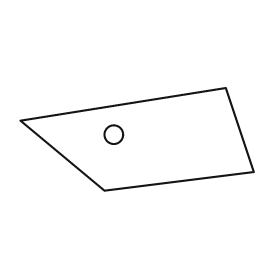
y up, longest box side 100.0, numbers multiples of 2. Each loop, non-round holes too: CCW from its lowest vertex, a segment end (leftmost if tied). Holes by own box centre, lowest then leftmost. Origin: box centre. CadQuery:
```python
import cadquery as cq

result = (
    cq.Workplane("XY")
    .moveTo(-14.0, -22.0)
    .lineTo(50.0, -14.0)
    .lineTo(38.0, 22.0)
    .lineTo(-50.0, 8.0)
    .close()
    .moveTo(-10.0, 2.0)
    .circle(4.0)
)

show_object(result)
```